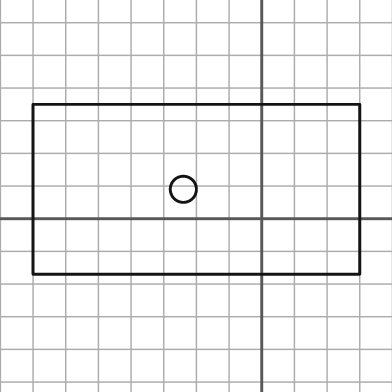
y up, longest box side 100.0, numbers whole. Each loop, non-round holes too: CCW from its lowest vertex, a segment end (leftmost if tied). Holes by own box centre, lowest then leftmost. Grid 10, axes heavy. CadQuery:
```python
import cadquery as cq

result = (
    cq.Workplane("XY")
    .moveTo(-70.0, -17.0)
    .lineTo(30.0, -17.0)
    .lineTo(30.0, 35.0)
    .lineTo(-70.0, 35.0)
    .close()
    .moveTo(-24.0, 9.0)
    .circle(4.0)
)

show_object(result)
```